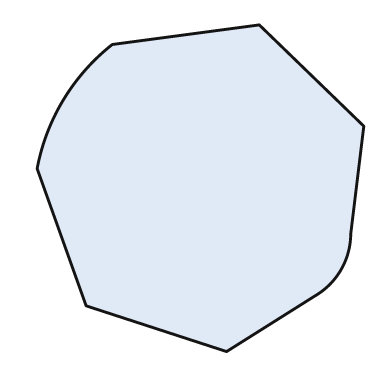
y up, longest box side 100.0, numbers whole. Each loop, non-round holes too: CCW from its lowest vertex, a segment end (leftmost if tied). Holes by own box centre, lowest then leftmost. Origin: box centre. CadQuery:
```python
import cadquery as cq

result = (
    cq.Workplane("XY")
    .moveTo(8.0, -50.0)
    .lineTo(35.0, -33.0)
    .threePointArc((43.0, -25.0), (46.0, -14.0))
    .lineTo(50.0, 19.0)
    .lineTo(18.0, 50.0)
    .lineTo(-27.0, 44.0)
    .threePointArc((-42.0, 27.0), (-50.0, 6.0))
    .lineTo(-35.0, -36.0)
    .close()
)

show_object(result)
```